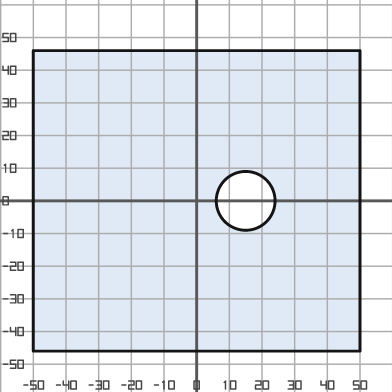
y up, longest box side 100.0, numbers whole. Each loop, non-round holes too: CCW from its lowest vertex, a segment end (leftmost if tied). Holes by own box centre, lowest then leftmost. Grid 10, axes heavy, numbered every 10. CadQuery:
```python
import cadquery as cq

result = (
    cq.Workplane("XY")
    .moveTo(-50.0, -46.0)
    .lineTo(50.0, -46.0)
    .lineTo(50.0, 46.0)
    .lineTo(-50.0, 46.0)
    .close()
    .moveTo(15.0, 0.0)
    .circle(9.0)
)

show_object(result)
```